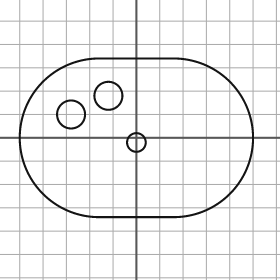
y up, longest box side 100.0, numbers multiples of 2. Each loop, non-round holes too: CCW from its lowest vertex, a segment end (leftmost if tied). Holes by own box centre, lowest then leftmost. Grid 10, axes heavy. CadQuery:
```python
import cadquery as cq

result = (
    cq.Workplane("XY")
    .moveTo(-16.0, -34.0)
    .lineTo(16.0, -34.0)
    .threePointArc((50.0, 0.0), (16.0, 34.0))
    .lineTo(-16.0, 34.0)
    .threePointArc((-50.0, 0.0), (-16.0, -34.0))
    .close()
    .moveTo(0.0, -2.0)
    .circle(4.0)
    .moveTo(-28.0, 10.0)
    .circle(6.0)
    .moveTo(-12.0, 18.0)
    .circle(6.0)
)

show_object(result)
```